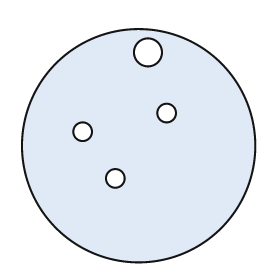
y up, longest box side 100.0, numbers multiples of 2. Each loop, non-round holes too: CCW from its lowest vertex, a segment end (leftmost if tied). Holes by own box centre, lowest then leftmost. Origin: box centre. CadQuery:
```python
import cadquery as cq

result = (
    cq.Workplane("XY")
    .moveTo(0.0, 0.0)
    .circle(50.0)
    .moveTo(-10.0, -14.0)
    .circle(4.0)
    .moveTo(-24.0, 6.0)
    .circle(4.0)
    .moveTo(12.0, 14.0)
    .circle(4.0)
    .moveTo(4.0, 40.0)
    .circle(6.0)
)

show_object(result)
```